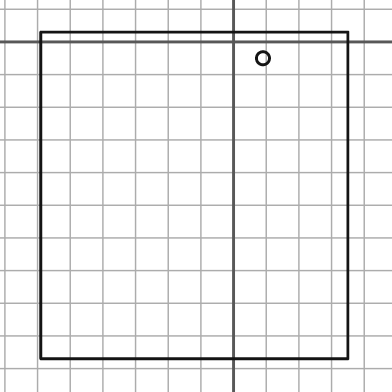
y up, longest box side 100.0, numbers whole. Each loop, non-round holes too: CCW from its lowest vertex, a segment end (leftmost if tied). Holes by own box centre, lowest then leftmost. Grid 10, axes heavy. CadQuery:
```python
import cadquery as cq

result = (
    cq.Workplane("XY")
    .moveTo(-59.0, -97.0)
    .lineTo(35.0, -97.0)
    .lineTo(35.0, 3.0)
    .lineTo(-59.0, 3.0)
    .close()
    .moveTo(9.0, -5.0)
    .circle(2.0)
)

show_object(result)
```